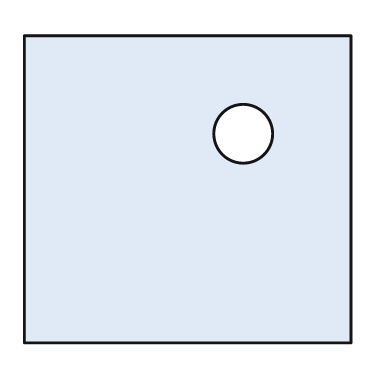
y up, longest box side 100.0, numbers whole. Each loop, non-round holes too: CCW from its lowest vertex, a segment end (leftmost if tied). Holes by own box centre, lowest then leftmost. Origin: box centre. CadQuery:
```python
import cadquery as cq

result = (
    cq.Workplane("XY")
    .moveTo(-50.0, -47.0)
    .lineTo(50.0, -47.0)
    .lineTo(50.0, 47.0)
    .lineTo(-50.0, 47.0)
    .close()
    .moveTo(17.0, 17.0)
    .circle(9.0)
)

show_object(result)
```